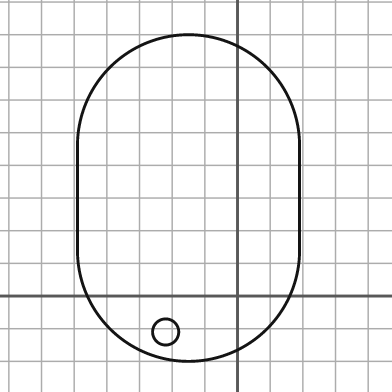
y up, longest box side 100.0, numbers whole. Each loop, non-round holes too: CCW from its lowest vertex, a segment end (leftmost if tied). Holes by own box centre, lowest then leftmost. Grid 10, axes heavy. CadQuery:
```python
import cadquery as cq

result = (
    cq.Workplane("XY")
    .moveTo(-49.0, 14.0)
    .threePointArc((-15.0, -20.0), (19.0, 14.0))
    .lineTo(19.0, 46.0)
    .threePointArc((-15.0, 80.0), (-49.0, 46.0))
    .close()
    .moveTo(-22.0, -11.0)
    .circle(4.0)
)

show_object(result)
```